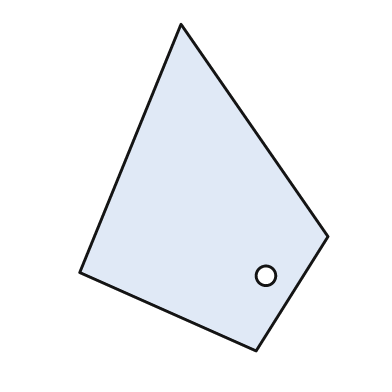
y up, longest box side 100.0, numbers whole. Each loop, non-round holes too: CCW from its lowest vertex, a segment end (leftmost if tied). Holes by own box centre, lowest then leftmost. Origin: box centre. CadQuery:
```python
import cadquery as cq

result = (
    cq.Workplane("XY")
    .moveTo(16.0, -50.0)
    .lineTo(38.0, -15.0)
    .lineTo(-7.0, 50.0)
    .lineTo(-38.0, -26.0)
    .close()
    .moveTo(19.0, -27.0)
    .circle(3.0)
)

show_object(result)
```